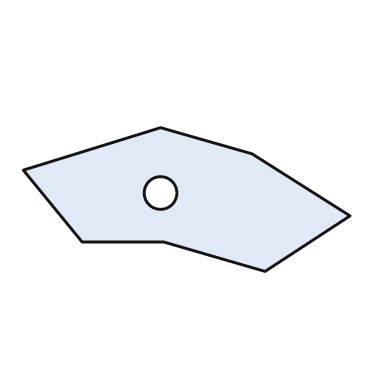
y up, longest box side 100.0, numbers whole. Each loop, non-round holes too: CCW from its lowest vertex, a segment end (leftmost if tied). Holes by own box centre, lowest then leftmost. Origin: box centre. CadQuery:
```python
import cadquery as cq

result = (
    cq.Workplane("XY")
    .moveTo(24.0, -22.0)
    .lineTo(50.0, -5.0)
    .lineTo(20.0, 14.0)
    .lineTo(-8.0, 22.0)
    .lineTo(-50.0, 9.0)
    .lineTo(-32.0, -13.0)
    .lineTo(-7.0, -13.0)
    .close()
    .moveTo(-8.0, 2.0)
    .circle(5.0)
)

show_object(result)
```